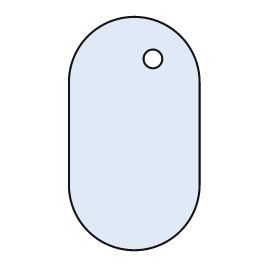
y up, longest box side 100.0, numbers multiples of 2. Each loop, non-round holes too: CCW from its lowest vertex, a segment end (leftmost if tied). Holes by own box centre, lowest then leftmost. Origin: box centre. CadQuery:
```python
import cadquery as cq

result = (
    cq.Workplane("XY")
    .moveTo(-28.0, -22.0)
    .threePointArc((0.0, -50.0), (28.0, -22.0))
    .lineTo(28.0, 22.0)
    .threePointArc((0.0, 50.0), (-28.0, 22.0))
    .close()
    .moveTo(8.0, 32.0)
    .circle(4.0)
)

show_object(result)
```